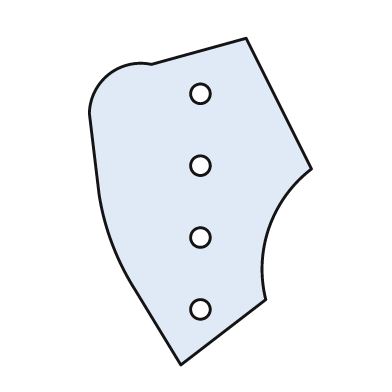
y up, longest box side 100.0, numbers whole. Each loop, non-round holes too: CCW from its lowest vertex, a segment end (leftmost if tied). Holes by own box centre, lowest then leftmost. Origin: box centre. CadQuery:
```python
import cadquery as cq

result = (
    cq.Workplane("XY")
    .moveTo(-6.0, -50.0)
    .lineTo(20.0, -30.0)
    .threePointArc((21.0, -8.0), (34.0, 10.0))
    .lineTo(14.0, 50.0)
    .lineTo(-15.0, 42.0)
    .threePointArc((-28.0, 39.0), (-34.0, 27.0))
    .lineTo(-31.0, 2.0)
    .threePointArc((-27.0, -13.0), (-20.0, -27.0))
    .close()
    .moveTo(0.0, -33.0)
    .circle(3.0)
    .moveTo(0.0, -11.0)
    .circle(3.0)
    .moveTo(0.0, 11.0)
    .circle(3.0)
    .moveTo(0.0, 33.0)
    .circle(3.0)
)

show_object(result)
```